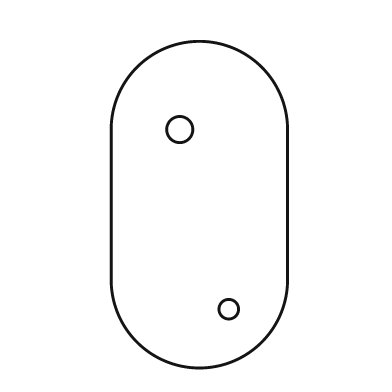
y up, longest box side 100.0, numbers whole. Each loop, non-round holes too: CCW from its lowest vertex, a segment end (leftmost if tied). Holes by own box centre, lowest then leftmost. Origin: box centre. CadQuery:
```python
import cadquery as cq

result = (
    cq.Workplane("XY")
    .moveTo(-27.0, -23.0)
    .threePointArc((0.0, -50.0), (27.0, -23.0))
    .lineTo(27.0, 23.0)
    .threePointArc((0.0, 50.0), (-27.0, 23.0))
    .close()
    .moveTo(9.0, -32.0)
    .circle(3.0)
    .moveTo(-6.0, 23.0)
    .circle(4.0)
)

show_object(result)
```